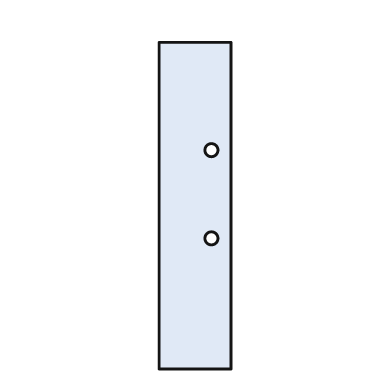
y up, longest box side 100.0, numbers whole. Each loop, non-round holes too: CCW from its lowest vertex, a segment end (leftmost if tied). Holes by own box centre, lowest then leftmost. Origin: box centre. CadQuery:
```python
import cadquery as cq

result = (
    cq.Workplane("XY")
    .moveTo(-11.0, -50.0)
    .lineTo(11.0, -50.0)
    .lineTo(11.0, 50.0)
    .lineTo(-11.0, 50.0)
    .close()
    .moveTo(5.0, -10.0)
    .circle(2.0)
    .moveTo(5.0, 17.0)
    .circle(2.0)
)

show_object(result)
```